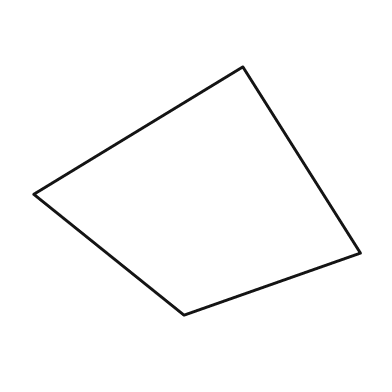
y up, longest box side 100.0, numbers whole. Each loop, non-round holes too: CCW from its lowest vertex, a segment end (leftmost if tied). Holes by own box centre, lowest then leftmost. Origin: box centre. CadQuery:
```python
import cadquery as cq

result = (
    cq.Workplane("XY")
    .moveTo(-4.0, -38.0)
    .lineTo(50.0, -19.0)
    .lineTo(14.0, 38.0)
    .lineTo(-50.0, -1.0)
    .close()
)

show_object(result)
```